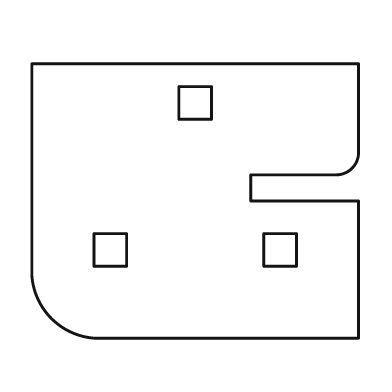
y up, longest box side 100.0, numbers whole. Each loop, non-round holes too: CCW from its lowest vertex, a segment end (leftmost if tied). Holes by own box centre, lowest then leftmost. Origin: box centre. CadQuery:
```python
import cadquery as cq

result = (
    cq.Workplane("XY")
    .moveTo(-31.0, -42.0)
    .lineTo(50.0, -42.0)
    .lineTo(50.0, 0.0)
    .lineTo(17.0, 0.0)
    .lineTo(17.0, 8.0)
    .lineTo(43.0, 8.0)
    .threePointArc((48.0, 10.0), (50.0, 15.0))
    .lineTo(50.0, 42.0)
    .lineTo(-50.0, 42.0)
    .lineTo(-50.0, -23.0)
    .threePointArc((-44.0, -36.0), (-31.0, -42.0))
    .close()
    .moveTo(-31.0, -20.0)
    .lineTo(-21.0, -20.0)
    .lineTo(-21.0, -10.0)
    .lineTo(-31.0, -10.0)
    .close()
    .moveTo(21.0, -20.0)
    .lineTo(31.0, -20.0)
    .lineTo(31.0, -10.0)
    .lineTo(21.0, -10.0)
    .close()
    .moveTo(-5.0, 25.0)
    .lineTo(5.0, 25.0)
    .lineTo(5.0, 35.0)
    .lineTo(-5.0, 35.0)
    .close()
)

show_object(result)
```